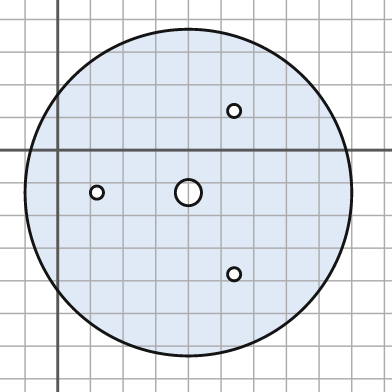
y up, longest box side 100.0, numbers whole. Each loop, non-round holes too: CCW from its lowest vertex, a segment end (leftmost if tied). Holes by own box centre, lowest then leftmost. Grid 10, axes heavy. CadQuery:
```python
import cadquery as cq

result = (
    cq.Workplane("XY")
    .moveTo(40.0, -13.0)
    .circle(50.0)
    .moveTo(54.0, -38.0)
    .circle(2.0)
    .moveTo(12.0, -13.0)
    .circle(2.0)
    .moveTo(40.0, -13.0)
    .circle(4.0)
    .moveTo(54.0, 12.0)
    .circle(2.0)
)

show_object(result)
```